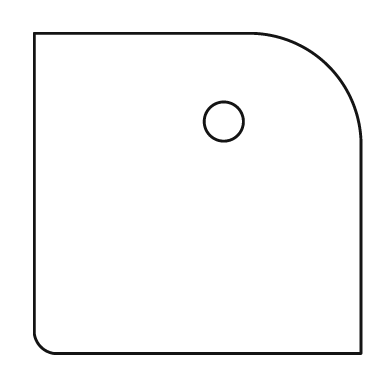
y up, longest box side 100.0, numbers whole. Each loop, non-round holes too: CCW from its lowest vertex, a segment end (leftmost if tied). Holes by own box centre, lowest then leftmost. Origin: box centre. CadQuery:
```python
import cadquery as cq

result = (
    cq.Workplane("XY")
    .moveTo(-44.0, -49.0)
    .lineTo(50.0, -49.0)
    .lineTo(50.0, 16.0)
    .threePointArc((40.0, 39.0), (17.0, 49.0))
    .lineTo(-50.0, 49.0)
    .lineTo(-50.0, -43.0)
    .threePointArc((-48.0, -47.0), (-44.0, -49.0))
    .close()
    .moveTo(8.0, 22.0)
    .circle(6.0)
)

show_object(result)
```